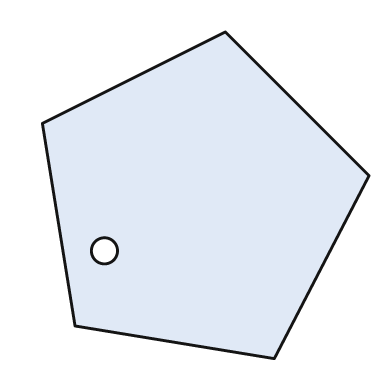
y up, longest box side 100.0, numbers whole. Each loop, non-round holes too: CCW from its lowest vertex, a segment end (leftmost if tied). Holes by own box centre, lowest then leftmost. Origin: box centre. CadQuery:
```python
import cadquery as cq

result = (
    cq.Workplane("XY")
    .moveTo(21.0, -50.0)
    .lineTo(50.0, 6.0)
    .lineTo(6.0, 50.0)
    .lineTo(-50.0, 22.0)
    .lineTo(-40.0, -40.0)
    .close()
    .moveTo(-31.0, -17.0)
    .circle(4.0)
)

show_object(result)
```